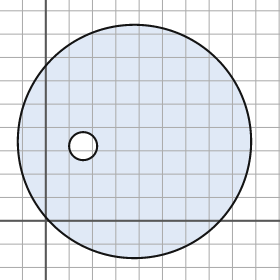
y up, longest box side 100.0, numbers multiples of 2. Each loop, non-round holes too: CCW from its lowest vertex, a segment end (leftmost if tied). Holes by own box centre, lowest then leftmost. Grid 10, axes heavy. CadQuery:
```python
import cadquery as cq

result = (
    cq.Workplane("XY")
    .moveTo(38.0, 34.0)
    .circle(50.0)
    .moveTo(16.0, 32.0)
    .circle(6.0)
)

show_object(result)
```